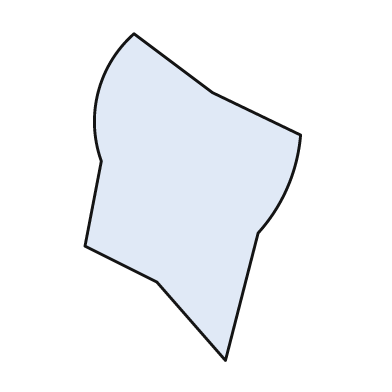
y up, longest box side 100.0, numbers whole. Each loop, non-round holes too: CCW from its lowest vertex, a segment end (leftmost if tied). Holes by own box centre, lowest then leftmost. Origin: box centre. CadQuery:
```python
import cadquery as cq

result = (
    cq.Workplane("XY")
    .moveTo(10.0, -50.0)
    .lineTo(20.0, -11.0)
    .threePointArc((29.0, 3.0), (33.0, 19.0))
    .lineTo(6.0, 32.0)
    .lineTo(-18.0, 50.0)
    .threePointArc((-29.0, 32.0), (-28.0, 11.0))
    .lineTo(-33.0, -15.0)
    .lineTo(-11.0, -26.0)
    .close()
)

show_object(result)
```